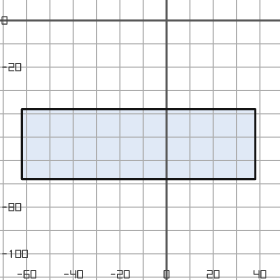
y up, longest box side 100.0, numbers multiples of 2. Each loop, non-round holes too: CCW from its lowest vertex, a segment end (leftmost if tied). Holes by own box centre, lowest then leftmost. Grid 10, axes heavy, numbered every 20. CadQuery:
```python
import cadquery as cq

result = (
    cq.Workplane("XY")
    .moveTo(-62.0, -68.0)
    .lineTo(38.0, -68.0)
    .lineTo(38.0, -38.0)
    .lineTo(-62.0, -38.0)
    .close()
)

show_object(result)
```